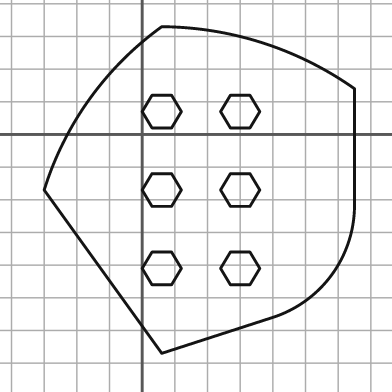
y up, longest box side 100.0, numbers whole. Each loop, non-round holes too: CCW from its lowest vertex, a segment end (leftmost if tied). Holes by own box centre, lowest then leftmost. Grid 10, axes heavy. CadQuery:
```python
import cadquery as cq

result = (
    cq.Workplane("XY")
    .moveTo(6.0, -67.0)
    .lineTo(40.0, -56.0)
    .threePointArc((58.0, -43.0), (65.0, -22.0))
    .lineTo(65.0, 14.0)
    .threePointArc((37.0, 28.0), (6.0, 33.0))
    .threePointArc((-16.0, 11.0), (-30.0, -17.0))
    .close()
    .moveTo(3.0, -46.0)
    .lineTo(9.0, -46.0)
    .lineTo(12.0, -41.0)
    .lineTo(9.0, -36.0)
    .lineTo(3.0, -36.0)
    .lineTo(0.0, -41.0)
    .close()
    .moveTo(27.0, -46.0)
    .lineTo(33.0, -46.0)
    .lineTo(36.0, -41.0)
    .lineTo(33.0, -36.0)
    .lineTo(27.0, -36.0)
    .lineTo(24.0, -41.0)
    .close()
    .moveTo(3.0, -22.0)
    .lineTo(9.0, -22.0)
    .lineTo(12.0, -17.0)
    .lineTo(9.0, -12.0)
    .lineTo(3.0, -12.0)
    .lineTo(0.0, -17.0)
    .close()
    .moveTo(27.0, -22.0)
    .lineTo(33.0, -22.0)
    .lineTo(36.0, -17.0)
    .lineTo(33.0, -12.0)
    .lineTo(27.0, -12.0)
    .lineTo(24.0, -17.0)
    .close()
    .moveTo(3.0, 2.0)
    .lineTo(9.0, 2.0)
    .lineTo(12.0, 7.0)
    .lineTo(9.0, 12.0)
    .lineTo(3.0, 12.0)
    .lineTo(0.0, 7.0)
    .close()
    .moveTo(27.0, 2.0)
    .lineTo(33.0, 2.0)
    .lineTo(36.0, 7.0)
    .lineTo(33.0, 12.0)
    .lineTo(27.0, 12.0)
    .lineTo(24.0, 7.0)
    .close()
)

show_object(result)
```